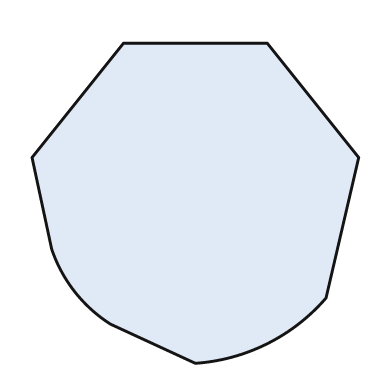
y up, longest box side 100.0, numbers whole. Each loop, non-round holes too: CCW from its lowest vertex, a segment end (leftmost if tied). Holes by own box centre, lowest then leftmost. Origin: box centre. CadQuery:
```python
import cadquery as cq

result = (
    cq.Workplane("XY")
    .moveTo(0.0, -49.0)
    .threePointArc((22.0, -43.0), (40.0, -29.0))
    .lineTo(50.0, 14.0)
    .lineTo(22.0, 49.0)
    .lineTo(-22.0, 49.0)
    .lineTo(-50.0, 14.0)
    .lineTo(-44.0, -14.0)
    .threePointArc((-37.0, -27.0), (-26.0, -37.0))
    .close()
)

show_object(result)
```